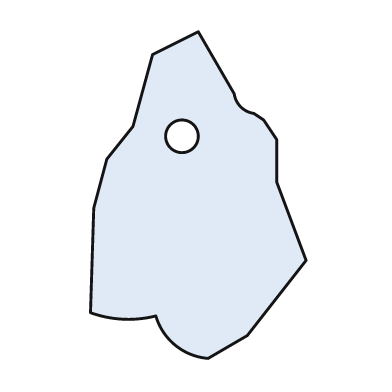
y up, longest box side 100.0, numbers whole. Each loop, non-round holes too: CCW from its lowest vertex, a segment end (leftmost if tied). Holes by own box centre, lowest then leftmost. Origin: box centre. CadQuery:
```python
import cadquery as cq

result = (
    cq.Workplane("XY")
    .moveTo(3.0, -50.0)
    .lineTo(15.0, -43.0)
    .lineTo(33.0, -20.0)
    .lineTo(24.0, 4.0)
    .lineTo(24.0, 17.0)
    .lineTo(20.0, 23.0)
    .lineTo(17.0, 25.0)
    .threePointArc((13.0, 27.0), (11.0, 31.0))
    .lineTo(0.0, 50.0)
    .lineTo(-14.0, 43.0)
    .lineTo(-20.0, 21.0)
    .lineTo(-28.0, 11.0)
    .lineTo(-32.0, -4.0)
    .lineTo(-33.0, -36.0)
    .threePointArc((-23.0, -38.0), (-13.0, -37.0))
    .threePointArc((-7.0, -46.0), (3.0, -50.0))
    .close()
    .moveTo(-5.0, 18.0)
    .circle(5.0)
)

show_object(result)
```